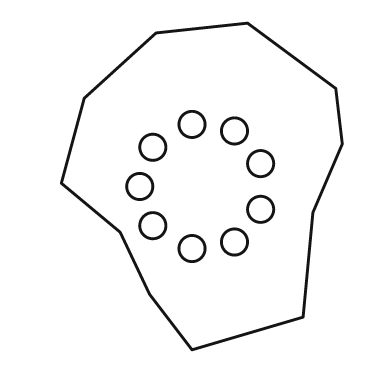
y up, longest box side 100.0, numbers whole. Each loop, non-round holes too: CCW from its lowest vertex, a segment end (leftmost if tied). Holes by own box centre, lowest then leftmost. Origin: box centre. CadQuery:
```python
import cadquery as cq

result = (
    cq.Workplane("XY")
    .moveTo(-3.0, -50.0)
    .lineTo(31.0, -40.0)
    .lineTo(34.0, -8.0)
    .lineTo(43.0, 13.0)
    .lineTo(41.0, 30.0)
    .lineTo(14.0, 50.0)
    .lineTo(-14.0, 47.0)
    .lineTo(-36.0, 27.0)
    .lineTo(-43.0, 1.0)
    .lineTo(-25.0, -14.0)
    .lineTo(-16.0, -33.0)
    .close()
    .moveTo(-3.0, -19.0)
    .circle(4.0)
    .moveTo(10.0, -17.0)
    .circle(4.0)
    .moveTo(-15.0, -12.0)
    .circle(4.0)
    .moveTo(18.0, -7.0)
    .circle(4.0)
    .moveTo(-19.0, 0.0)
    .circle(4.0)
    .moveTo(18.0, 7.0)
    .circle(4.0)
    .moveTo(-15.0, 12.0)
    .circle(4.0)
    .moveTo(10.0, 17.0)
    .circle(4.0)
    .moveTo(-3.0, 19.0)
    .circle(4.0)
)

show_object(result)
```